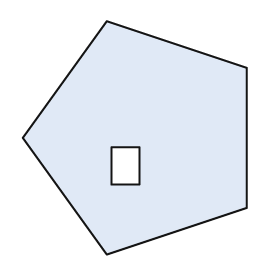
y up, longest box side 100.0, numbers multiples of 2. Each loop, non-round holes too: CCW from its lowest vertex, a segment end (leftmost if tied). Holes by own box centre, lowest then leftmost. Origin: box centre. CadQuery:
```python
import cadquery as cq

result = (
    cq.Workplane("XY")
    .moveTo(-12.0, -50.0)
    .lineTo(48.0, -30.0)
    .lineTo(48.0, 30.0)
    .lineTo(-12.0, 50.0)
    .lineTo(-48.0, 0.0)
    .close()
    .moveTo(-10.0, -20.0)
    .lineTo(2.0, -20.0)
    .lineTo(2.0, -4.0)
    .lineTo(-10.0, -4.0)
    .close()
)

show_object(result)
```